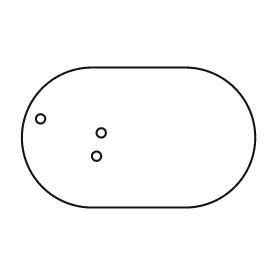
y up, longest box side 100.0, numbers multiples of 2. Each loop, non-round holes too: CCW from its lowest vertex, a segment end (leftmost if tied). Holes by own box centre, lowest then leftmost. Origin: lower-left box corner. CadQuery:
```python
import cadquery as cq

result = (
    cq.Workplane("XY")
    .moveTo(30.0, 0.0)
    .lineTo(70.0, 0.0)
    .threePointArc((100.0, 30.0), (70.0, 60.0))
    .lineTo(30.0, 60.0)
    .threePointArc((0.0, 30.0), (30.0, 0.0))
    .close()
    .moveTo(32.0, 22.0)
    .circle(2.0)
    .moveTo(34.0, 32.0)
    .circle(2.0)
    .moveTo(8.0, 38.0)
    .circle(2.0)
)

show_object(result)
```